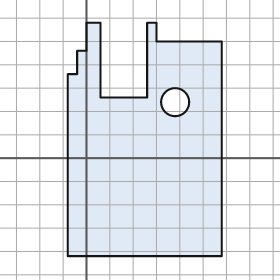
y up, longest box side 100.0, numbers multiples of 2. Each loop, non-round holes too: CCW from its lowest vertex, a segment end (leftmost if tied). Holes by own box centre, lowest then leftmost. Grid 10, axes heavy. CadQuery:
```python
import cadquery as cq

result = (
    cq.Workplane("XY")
    .moveTo(-8.0, -42.0)
    .lineTo(58.0, -42.0)
    .lineTo(58.0, 50.0)
    .lineTo(30.0, 50.0)
    .lineTo(30.0, 58.0)
    .lineTo(26.0, 58.0)
    .lineTo(26.0, 26.0)
    .lineTo(6.0, 26.0)
    .lineTo(6.0, 58.0)
    .lineTo(0.0, 58.0)
    .lineTo(0.0, 46.0)
    .lineTo(-4.0, 46.0)
    .lineTo(-4.0, 36.0)
    .lineTo(-8.0, 36.0)
    .close()
    .moveTo(38.0, 24.0)
    .circle(6.0)
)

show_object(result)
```